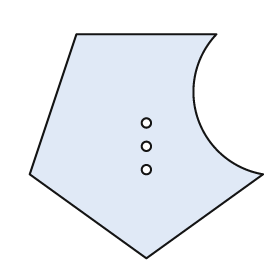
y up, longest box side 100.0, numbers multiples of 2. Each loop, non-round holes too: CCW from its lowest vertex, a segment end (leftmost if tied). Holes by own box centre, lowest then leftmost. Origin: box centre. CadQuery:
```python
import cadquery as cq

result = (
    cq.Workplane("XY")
    .moveTo(0.0, -48.0)
    .lineTo(50.0, -12.0)
    .threePointArc((22.0, 12.0), (30.0, 48.0))
    .lineTo(-30.0, 48.0)
    .lineTo(-50.0, -12.0)
    .close()
    .moveTo(0.0, -10.0)
    .circle(2.0)
    .moveTo(0.0, 0.0)
    .circle(2.0)
    .moveTo(0.0, 10.0)
    .circle(2.0)
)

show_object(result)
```